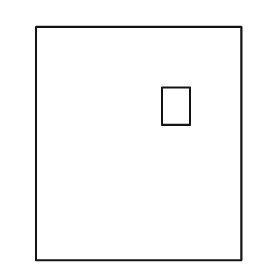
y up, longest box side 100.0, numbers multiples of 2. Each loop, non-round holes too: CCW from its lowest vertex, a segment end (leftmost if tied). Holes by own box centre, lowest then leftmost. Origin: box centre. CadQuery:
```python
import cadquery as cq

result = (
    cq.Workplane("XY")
    .moveTo(-44.0, -50.0)
    .lineTo(44.0, -50.0)
    .lineTo(44.0, 50.0)
    .lineTo(-44.0, 50.0)
    .close()
    .moveTo(10.0, 8.0)
    .lineTo(22.0, 8.0)
    .lineTo(22.0, 24.0)
    .lineTo(10.0, 24.0)
    .close()
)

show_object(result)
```